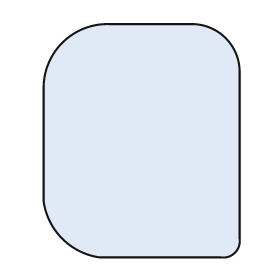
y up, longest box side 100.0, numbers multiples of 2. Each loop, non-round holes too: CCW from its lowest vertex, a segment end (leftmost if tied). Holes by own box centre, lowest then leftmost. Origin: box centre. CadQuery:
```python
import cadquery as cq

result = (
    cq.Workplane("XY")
    .moveTo(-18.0, -50.0)
    .lineTo(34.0, -50.0)
    .threePointArc((40.0, -48.0), (42.0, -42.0))
    .lineTo(42.0, 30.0)
    .threePointArc((36.0, 44.0), (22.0, 50.0))
    .lineTo(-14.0, 50.0)
    .threePointArc((-34.0, 42.0), (-42.0, 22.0))
    .lineTo(-42.0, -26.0)
    .threePointArc((-34.0, -42.0), (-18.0, -50.0))
    .close()
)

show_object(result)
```